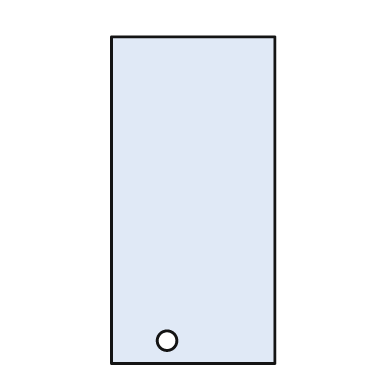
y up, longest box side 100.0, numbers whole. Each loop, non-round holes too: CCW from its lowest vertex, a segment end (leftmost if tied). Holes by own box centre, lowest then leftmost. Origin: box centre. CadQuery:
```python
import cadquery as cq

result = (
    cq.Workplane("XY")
    .moveTo(-25.0, -50.0)
    .lineTo(25.0, -50.0)
    .lineTo(25.0, 50.0)
    .lineTo(-25.0, 50.0)
    .close()
    .moveTo(-8.0, -43.0)
    .circle(3.0)
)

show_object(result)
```